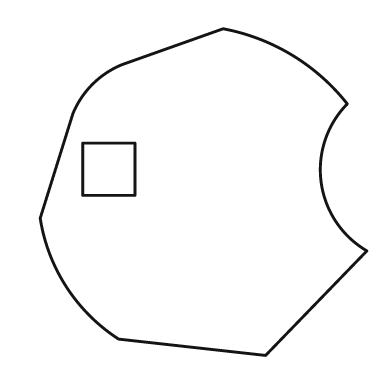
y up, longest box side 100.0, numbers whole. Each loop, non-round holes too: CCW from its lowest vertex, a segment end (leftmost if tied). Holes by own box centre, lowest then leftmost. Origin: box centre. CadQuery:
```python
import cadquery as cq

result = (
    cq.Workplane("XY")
    .moveTo(19.0, -50.0)
    .lineTo(50.0, -18.0)
    .threePointArc((36.0, 3.0), (44.0, 27.0))
    .threePointArc((27.0, 42.0), (6.0, 50.0))
    .lineTo(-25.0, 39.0)
    .threePointArc((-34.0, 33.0), (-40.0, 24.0))
    .lineTo(-50.0, -8.0)
    .threePointArc((-42.0, -29.0), (-26.0, -45.0))
    .close()
    .moveTo(-37.0, -1.0)
    .lineTo(-21.0, -1.0)
    .lineTo(-21.0, 15.0)
    .lineTo(-37.0, 15.0)
    .close()
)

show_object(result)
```